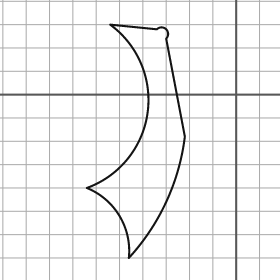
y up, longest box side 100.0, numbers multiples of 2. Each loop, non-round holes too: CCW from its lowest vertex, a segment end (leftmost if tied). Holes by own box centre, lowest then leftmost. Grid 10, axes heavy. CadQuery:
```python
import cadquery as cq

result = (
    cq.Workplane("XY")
    .moveTo(-46.0, -70.0)
    .threePointArc((-30.0, -46.0), (-22.0, -18.0))
    .lineTo(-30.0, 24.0)
    .threePointArc((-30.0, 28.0), (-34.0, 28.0))
    .lineTo(-54.0, 30.0)
    .threePointArc((-38.0, -8.0), (-64.0, -40.0))
    .threePointArc((-50.0, -52.0), (-46.0, -70.0))
    .close()
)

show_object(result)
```